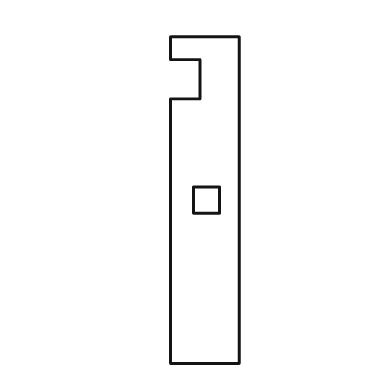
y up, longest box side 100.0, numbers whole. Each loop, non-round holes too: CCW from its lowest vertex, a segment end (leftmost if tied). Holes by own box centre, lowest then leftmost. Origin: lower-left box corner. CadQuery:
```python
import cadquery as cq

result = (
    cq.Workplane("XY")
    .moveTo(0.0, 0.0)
    .lineTo(21.0, 0.0)
    .lineTo(21.0, 100.0)
    .lineTo(0.0, 100.0)
    .lineTo(0.0, 93.0)
    .lineTo(9.0, 93.0)
    .lineTo(9.0, 81.0)
    .lineTo(0.0, 81.0)
    .close()
    .moveTo(7.0, 46.0)
    .lineTo(15.0, 46.0)
    .lineTo(15.0, 54.0)
    .lineTo(7.0, 54.0)
    .close()
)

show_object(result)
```